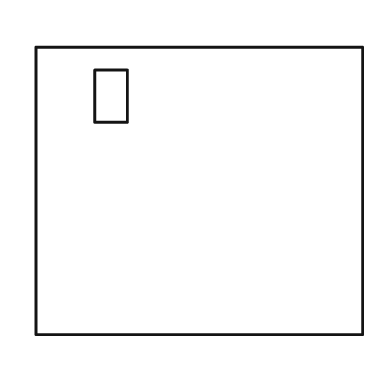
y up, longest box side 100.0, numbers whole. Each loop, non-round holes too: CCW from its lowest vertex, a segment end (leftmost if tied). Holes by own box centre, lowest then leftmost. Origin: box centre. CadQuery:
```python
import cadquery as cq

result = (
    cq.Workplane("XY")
    .moveTo(-50.0, -44.0)
    .lineTo(50.0, -44.0)
    .lineTo(50.0, 44.0)
    .lineTo(-50.0, 44.0)
    .close()
    .moveTo(-32.0, 21.0)
    .lineTo(-22.0, 21.0)
    .lineTo(-22.0, 37.0)
    .lineTo(-32.0, 37.0)
    .close()
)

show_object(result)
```